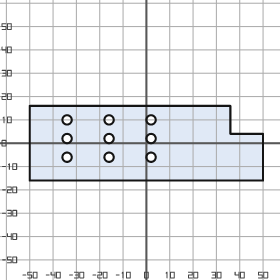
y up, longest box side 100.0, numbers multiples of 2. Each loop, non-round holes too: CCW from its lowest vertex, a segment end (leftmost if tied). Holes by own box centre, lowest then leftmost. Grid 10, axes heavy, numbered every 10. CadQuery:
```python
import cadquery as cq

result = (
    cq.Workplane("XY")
    .moveTo(-50.0, -16.0)
    .lineTo(50.0, -16.0)
    .lineTo(50.0, 4.0)
    .lineTo(36.0, 4.0)
    .lineTo(36.0, 16.0)
    .lineTo(-50.0, 16.0)
    .close()
    .moveTo(-34.0, -6.0)
    .circle(2.0)
    .moveTo(-16.0, -6.0)
    .circle(2.0)
    .moveTo(2.0, -6.0)
    .circle(2.0)
    .moveTo(-34.0, 2.0)
    .circle(2.0)
    .moveTo(-16.0, 2.0)
    .circle(2.0)
    .moveTo(2.0, 2.0)
    .circle(2.0)
    .moveTo(-34.0, 10.0)
    .circle(2.0)
    .moveTo(-16.0, 10.0)
    .circle(2.0)
    .moveTo(2.0, 10.0)
    .circle(2.0)
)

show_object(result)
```